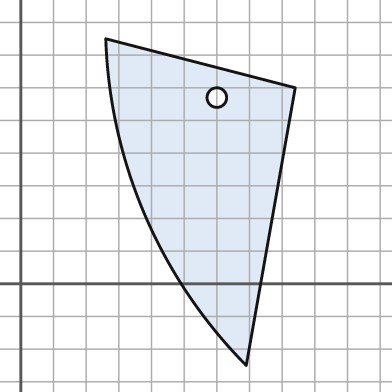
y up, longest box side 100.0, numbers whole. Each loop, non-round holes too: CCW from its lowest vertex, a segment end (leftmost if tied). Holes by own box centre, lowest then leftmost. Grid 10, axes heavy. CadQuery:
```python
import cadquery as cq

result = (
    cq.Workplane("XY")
    .moveTo(69.0, -25.0)
    .lineTo(84.0, 60.0)
    .lineTo(26.0, 75.0)
    .threePointArc((38.0, 21.0), (69.0, -25.0))
    .close()
    .moveTo(60.0, 57.0)
    .circle(3.0)
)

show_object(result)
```